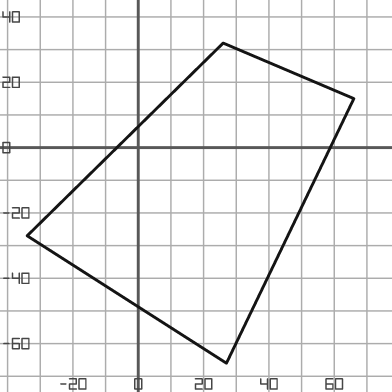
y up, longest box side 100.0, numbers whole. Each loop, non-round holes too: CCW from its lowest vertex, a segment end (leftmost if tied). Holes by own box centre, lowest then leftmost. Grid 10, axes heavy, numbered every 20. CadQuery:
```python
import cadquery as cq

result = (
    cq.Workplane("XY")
    .moveTo(27.0, -66.0)
    .lineTo(66.0, 15.0)
    .lineTo(26.0, 32.0)
    .lineTo(-34.0, -27.0)
    .close()
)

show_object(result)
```